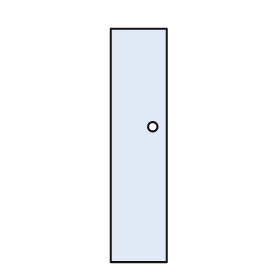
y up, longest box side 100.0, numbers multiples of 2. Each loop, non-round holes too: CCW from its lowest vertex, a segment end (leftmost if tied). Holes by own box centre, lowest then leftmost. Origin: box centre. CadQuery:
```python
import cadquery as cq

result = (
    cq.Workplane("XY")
    .moveTo(-12.0, -50.0)
    .lineTo(12.0, -50.0)
    .lineTo(12.0, 50.0)
    .lineTo(-12.0, 50.0)
    .close()
    .moveTo(6.0, 8.0)
    .circle(2.0)
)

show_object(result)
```